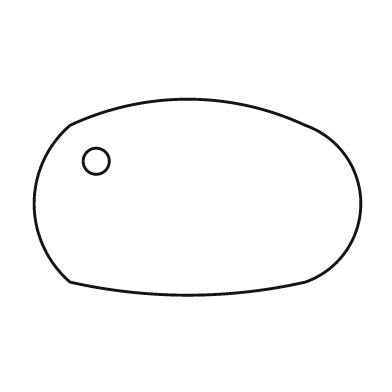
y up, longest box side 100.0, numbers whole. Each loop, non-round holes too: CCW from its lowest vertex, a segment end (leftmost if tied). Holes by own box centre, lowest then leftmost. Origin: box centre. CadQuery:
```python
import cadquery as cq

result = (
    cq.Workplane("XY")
    .moveTo(-39.0, -26.0)
    .threePointArc((-3.0, -30.0), (33.0, -26.0))
    .threePointArc((50.0, -2.0), (33.0, 22.0))
    .threePointArc((-3.0, 30.0), (-39.0, 22.0))
    .threePointArc((-50.0, -2.0), (-39.0, -26.0))
    .close()
    .moveTo(-31.0, 11.0)
    .circle(4.0)
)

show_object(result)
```